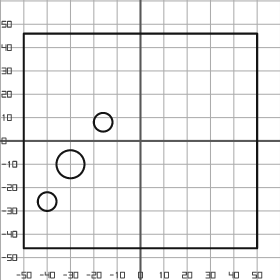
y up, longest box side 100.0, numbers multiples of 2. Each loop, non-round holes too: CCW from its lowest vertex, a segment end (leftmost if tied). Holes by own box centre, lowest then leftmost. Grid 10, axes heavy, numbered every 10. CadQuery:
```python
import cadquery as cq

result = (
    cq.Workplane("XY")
    .moveTo(-50.0, -46.0)
    .lineTo(50.0, -46.0)
    .lineTo(50.0, 46.0)
    .lineTo(-50.0, 46.0)
    .close()
    .moveTo(-40.0, -26.0)
    .circle(4.0)
    .moveTo(-30.0, -10.0)
    .circle(6.0)
    .moveTo(-16.0, 8.0)
    .circle(4.0)
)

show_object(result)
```